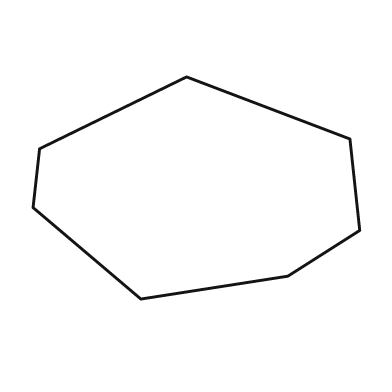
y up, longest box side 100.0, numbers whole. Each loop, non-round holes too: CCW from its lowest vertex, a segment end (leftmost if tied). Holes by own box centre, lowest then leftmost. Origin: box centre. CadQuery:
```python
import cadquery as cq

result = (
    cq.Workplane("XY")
    .moveTo(-17.0, -34.0)
    .lineTo(28.0, -27.0)
    .lineTo(50.0, -13.0)
    .lineTo(47.0, 15.0)
    .lineTo(-3.0, 34.0)
    .lineTo(-48.0, 12.0)
    .lineTo(-50.0, -6.0)
    .close()
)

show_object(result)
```